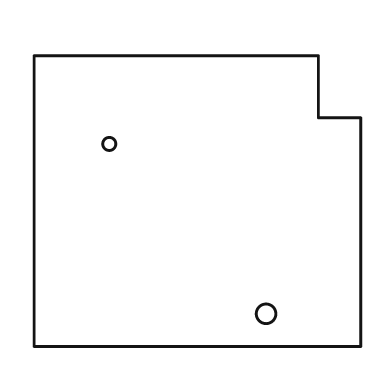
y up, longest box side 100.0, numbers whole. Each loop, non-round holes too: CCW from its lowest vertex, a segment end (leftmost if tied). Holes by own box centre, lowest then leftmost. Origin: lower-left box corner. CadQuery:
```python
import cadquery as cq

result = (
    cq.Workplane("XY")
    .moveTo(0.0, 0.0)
    .lineTo(100.0, 0.0)
    .lineTo(100.0, 70.0)
    .lineTo(87.0, 70.0)
    .lineTo(87.0, 89.0)
    .lineTo(0.0, 89.0)
    .close()
    .moveTo(71.0, 10.0)
    .circle(3.0)
    .moveTo(23.0, 62.0)
    .circle(2.0)
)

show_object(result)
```